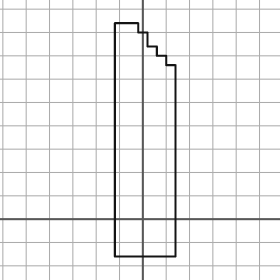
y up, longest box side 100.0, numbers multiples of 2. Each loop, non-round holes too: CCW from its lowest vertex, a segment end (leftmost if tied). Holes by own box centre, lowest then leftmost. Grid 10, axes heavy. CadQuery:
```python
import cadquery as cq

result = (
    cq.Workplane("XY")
    .moveTo(-12.0, -16.0)
    .lineTo(14.0, -16.0)
    .lineTo(14.0, 66.0)
    .lineTo(10.0, 66.0)
    .lineTo(10.0, 70.0)
    .lineTo(6.0, 70.0)
    .lineTo(6.0, 74.0)
    .lineTo(2.0, 74.0)
    .lineTo(2.0, 80.0)
    .lineTo(-2.0, 80.0)
    .lineTo(-2.0, 84.0)
    .lineTo(-12.0, 84.0)
    .close()
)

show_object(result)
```